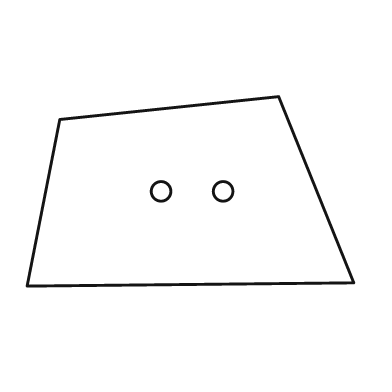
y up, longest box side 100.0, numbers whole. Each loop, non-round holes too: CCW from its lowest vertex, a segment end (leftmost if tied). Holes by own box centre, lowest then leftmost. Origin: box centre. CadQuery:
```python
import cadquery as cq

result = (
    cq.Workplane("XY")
    .moveTo(-50.0, -29.0)
    .lineTo(50.0, -28.0)
    .lineTo(27.0, 29.0)
    .lineTo(-40.0, 22.0)
    .close()
    .moveTo(-9.0, 0.0)
    .circle(3.0)
    .moveTo(10.0, 0.0)
    .circle(3.0)
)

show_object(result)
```